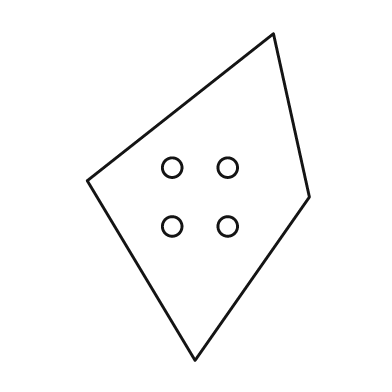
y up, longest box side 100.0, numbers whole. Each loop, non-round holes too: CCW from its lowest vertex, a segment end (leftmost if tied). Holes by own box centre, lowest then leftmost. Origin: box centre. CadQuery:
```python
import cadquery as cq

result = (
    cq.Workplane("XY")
    .moveTo(-1.0, -50.0)
    .lineTo(34.0, 0.0)
    .lineTo(23.0, 50.0)
    .lineTo(-34.0, 5.0)
    .close()
    .moveTo(-8.0, -9.0)
    .circle(3.0)
    .moveTo(9.0, -9.0)
    .circle(3.0)
    .moveTo(-8.0, 9.0)
    .circle(3.0)
    .moveTo(9.0, 9.0)
    .circle(3.0)
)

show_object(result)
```